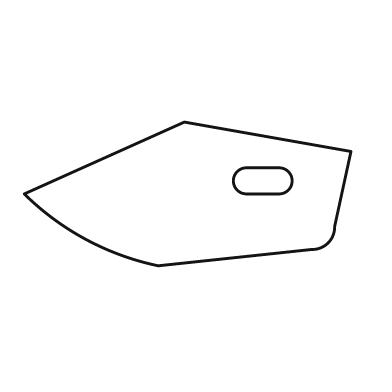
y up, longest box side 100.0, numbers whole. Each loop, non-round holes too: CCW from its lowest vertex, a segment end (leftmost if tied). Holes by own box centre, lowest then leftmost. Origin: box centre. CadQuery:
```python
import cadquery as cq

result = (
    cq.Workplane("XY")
    .moveTo(-9.0, -22.0)
    .lineTo(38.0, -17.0)
    .threePointArc((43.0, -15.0), (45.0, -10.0))
    .lineTo(50.0, 13.0)
    .lineTo(-1.0, 22.0)
    .lineTo(-50.0, 0.0)
    .threePointArc((-31.0, -14.0), (-9.0, -22.0))
    .close()
    .moveTo(18.0, 0.0)
    .lineTo(28.0, 0.0)
    .threePointArc((32.0, 4.0), (28.0, 8.0))
    .lineTo(18.0, 8.0)
    .threePointArc((14.0, 4.0), (18.0, 0.0))
    .close()
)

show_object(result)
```